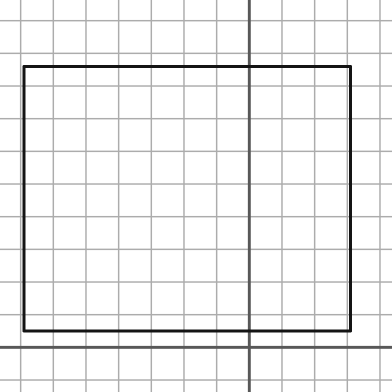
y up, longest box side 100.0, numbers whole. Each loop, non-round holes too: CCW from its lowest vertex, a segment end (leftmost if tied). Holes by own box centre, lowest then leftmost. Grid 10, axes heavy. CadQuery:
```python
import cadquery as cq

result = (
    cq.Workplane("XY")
    .moveTo(-69.0, 5.0)
    .lineTo(31.0, 5.0)
    .lineTo(31.0, 86.0)
    .lineTo(-69.0, 86.0)
    .close()
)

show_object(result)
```